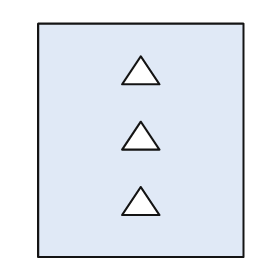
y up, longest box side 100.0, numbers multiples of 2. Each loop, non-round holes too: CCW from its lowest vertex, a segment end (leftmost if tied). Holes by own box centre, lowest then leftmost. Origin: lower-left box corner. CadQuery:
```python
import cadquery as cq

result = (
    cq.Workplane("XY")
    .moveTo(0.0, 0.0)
    .lineTo(88.0, 0.0)
    .lineTo(88.0, 100.0)
    .lineTo(0.0, 100.0)
    .close()
    .moveTo(36.0, 18.0)
    .lineTo(52.0, 18.0)
    .lineTo(44.0, 30.0)
    .close()
    .moveTo(36.0, 46.0)
    .lineTo(52.0, 46.0)
    .lineTo(44.0, 58.0)
    .close()
    .moveTo(36.0, 74.0)
    .lineTo(52.0, 74.0)
    .lineTo(44.0, 86.0)
    .close()
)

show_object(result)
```